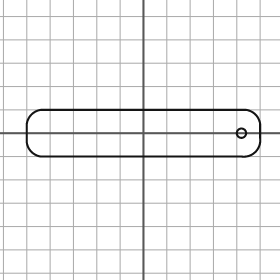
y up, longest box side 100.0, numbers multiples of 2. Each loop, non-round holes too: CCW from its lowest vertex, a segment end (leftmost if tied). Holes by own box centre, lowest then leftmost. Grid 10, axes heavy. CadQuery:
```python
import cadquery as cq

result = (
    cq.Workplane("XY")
    .moveTo(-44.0, -10.0)
    .lineTo(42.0, -10.0)
    .threePointArc((48.0, -8.0), (50.0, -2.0))
    .lineTo(50.0, 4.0)
    .threePointArc((48.0, 8.0), (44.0, 10.0))
    .lineTo(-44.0, 10.0)
    .threePointArc((-48.0, 8.0), (-50.0, 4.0))
    .lineTo(-50.0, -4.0)
    .threePointArc((-48.0, -8.0), (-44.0, -10.0))
    .close()
    .moveTo(42.0, 0.0)
    .circle(2.0)
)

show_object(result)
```